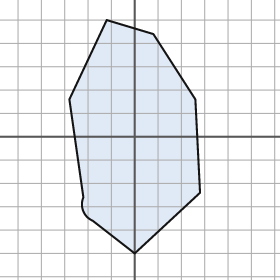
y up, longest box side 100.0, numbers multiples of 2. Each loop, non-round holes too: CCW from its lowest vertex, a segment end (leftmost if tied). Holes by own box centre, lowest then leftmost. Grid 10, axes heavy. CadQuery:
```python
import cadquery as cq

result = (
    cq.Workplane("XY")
    .moveTo(0.0, -50.0)
    .lineTo(28.0, -24.0)
    .lineTo(26.0, 16.0)
    .lineTo(8.0, 44.0)
    .lineTo(-12.0, 50.0)
    .lineTo(-28.0, 16.0)
    .lineTo(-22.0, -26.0)
    .threePointArc((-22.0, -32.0), (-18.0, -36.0))
    .close()
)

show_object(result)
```